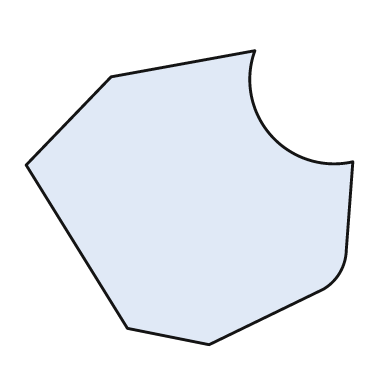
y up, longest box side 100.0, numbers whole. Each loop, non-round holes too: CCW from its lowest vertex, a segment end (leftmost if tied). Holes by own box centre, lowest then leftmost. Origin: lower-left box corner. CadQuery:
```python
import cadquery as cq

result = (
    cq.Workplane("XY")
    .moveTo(56.0, 0.0)
    .lineTo(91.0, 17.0)
    .threePointArc((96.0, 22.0), (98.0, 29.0))
    .lineTo(100.0, 56.0)
    .threePointArc((75.0, 64.0), (70.0, 90.0))
    .lineTo(26.0, 82.0)
    .lineTo(0.0, 55.0)
    .lineTo(31.0, 5.0)
    .close()
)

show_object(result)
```